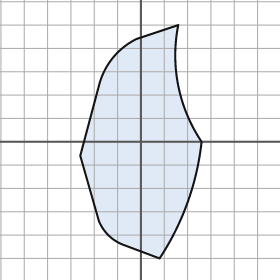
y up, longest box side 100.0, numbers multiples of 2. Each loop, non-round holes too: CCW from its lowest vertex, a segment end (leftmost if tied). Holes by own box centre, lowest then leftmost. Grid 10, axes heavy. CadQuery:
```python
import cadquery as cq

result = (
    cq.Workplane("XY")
    .moveTo(8.0, -50.0)
    .threePointArc((20.0, -26.0), (26.0, 0.0))
    .threePointArc((16.0, 24.0), (16.0, 50.0))
    .lineTo(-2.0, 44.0)
    .threePointArc((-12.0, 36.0), (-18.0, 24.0))
    .lineTo(-26.0, -6.0)
    .lineTo(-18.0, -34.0)
    .threePointArc((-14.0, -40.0), (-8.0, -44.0))
    .close()
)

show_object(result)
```